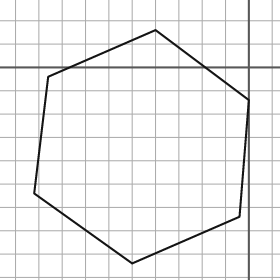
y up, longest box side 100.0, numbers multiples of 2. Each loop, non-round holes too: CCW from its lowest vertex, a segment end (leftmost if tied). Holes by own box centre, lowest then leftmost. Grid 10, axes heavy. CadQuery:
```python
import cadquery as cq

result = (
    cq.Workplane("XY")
    .moveTo(-50.0, -84.0)
    .lineTo(-4.0, -64.0)
    .lineTo(0.0, -14.0)
    .lineTo(-40.0, 16.0)
    .lineTo(-86.0, -4.0)
    .lineTo(-92.0, -54.0)
    .close()
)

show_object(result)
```